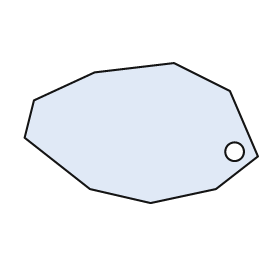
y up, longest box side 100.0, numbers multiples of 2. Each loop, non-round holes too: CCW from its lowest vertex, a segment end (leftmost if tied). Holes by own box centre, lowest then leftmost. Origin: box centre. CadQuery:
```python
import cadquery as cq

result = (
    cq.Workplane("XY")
    .moveTo(4.0, -30.0)
    .lineTo(32.0, -24.0)
    .lineTo(50.0, -10.0)
    .lineTo(38.0, 18.0)
    .lineTo(14.0, 30.0)
    .lineTo(-20.0, 26.0)
    .lineTo(-46.0, 14.0)
    .lineTo(-50.0, -2.0)
    .lineTo(-22.0, -24.0)
    .close()
    .moveTo(40.0, -8.0)
    .circle(4.0)
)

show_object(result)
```